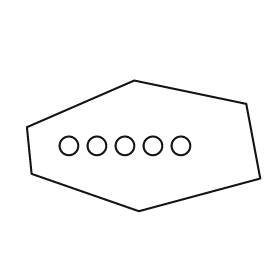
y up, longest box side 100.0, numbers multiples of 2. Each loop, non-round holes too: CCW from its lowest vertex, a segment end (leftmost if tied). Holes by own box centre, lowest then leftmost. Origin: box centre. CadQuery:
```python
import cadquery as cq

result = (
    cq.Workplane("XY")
    .moveTo(-2.0, -28.0)
    .lineTo(50.0, -14.0)
    .lineTo(44.0, 18.0)
    .lineTo(-4.0, 28.0)
    .lineTo(-50.0, 8.0)
    .lineTo(-48.0, -12.0)
    .close()
    .moveTo(-32.0, 0.0)
    .circle(4.0)
    .moveTo(-20.0, 0.0)
    .circle(4.0)
    .moveTo(-8.0, 0.0)
    .circle(4.0)
    .moveTo(4.0, 0.0)
    .circle(4.0)
    .moveTo(16.0, 0.0)
    .circle(4.0)
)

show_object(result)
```